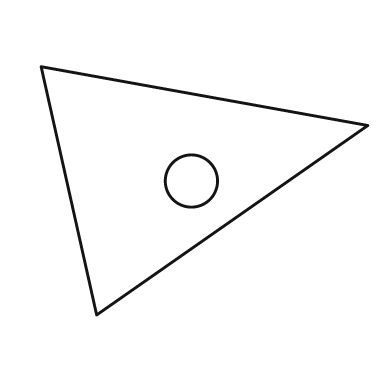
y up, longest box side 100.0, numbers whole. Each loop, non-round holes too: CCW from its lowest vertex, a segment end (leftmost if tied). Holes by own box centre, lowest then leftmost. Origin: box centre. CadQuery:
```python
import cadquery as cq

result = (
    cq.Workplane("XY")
    .moveTo(-33.0, -38.0)
    .lineTo(50.0, 20.0)
    .lineTo(-50.0, 38.0)
    .close()
    .moveTo(-4.0, 3.0)
    .circle(8.0)
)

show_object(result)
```